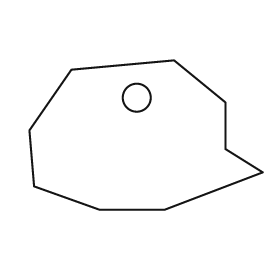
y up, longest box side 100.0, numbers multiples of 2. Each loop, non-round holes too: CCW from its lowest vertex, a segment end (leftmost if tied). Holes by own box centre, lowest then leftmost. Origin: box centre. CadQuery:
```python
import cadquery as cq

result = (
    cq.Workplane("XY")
    .moveTo(-20.0, -32.0)
    .lineTo(8.0, -32.0)
    .lineTo(50.0, -16.0)
    .lineTo(34.0, -6.0)
    .lineTo(34.0, 14.0)
    .lineTo(12.0, 32.0)
    .lineTo(-32.0, 28.0)
    .lineTo(-50.0, 2.0)
    .lineTo(-48.0, -22.0)
    .close()
    .moveTo(-4.0, 16.0)
    .circle(6.0)
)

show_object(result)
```